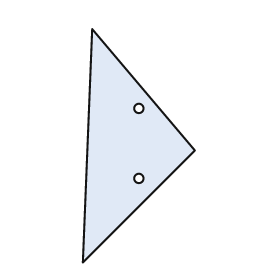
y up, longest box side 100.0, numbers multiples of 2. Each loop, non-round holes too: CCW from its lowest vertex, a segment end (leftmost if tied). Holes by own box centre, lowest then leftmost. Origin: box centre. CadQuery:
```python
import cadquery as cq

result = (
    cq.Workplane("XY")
    .moveTo(-24.0, -50.0)
    .lineTo(24.0, -2.0)
    .lineTo(-20.0, 50.0)
    .close()
    .moveTo(0.0, -14.0)
    .circle(2.0)
    .moveTo(0.0, 16.0)
    .circle(2.0)
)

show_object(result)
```